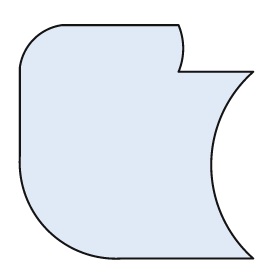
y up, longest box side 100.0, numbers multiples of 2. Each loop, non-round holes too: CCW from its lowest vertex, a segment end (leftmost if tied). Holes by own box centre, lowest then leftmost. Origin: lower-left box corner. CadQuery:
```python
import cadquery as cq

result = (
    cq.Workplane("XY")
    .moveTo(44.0, 0.0)
    .lineTo(100.0, 0.0)
    .threePointArc((82.0, 40.0), (100.0, 80.0))
    .lineTo(68.0, 80.0)
    .threePointArc((70.0, 90.0), (68.0, 100.0))
    .lineTo(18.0, 100.0)
    .threePointArc((6.0, 94.0), (0.0, 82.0))
    .lineTo(0.0, 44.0)
    .threePointArc((12.0, 12.0), (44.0, 0.0))
    .close()
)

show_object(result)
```